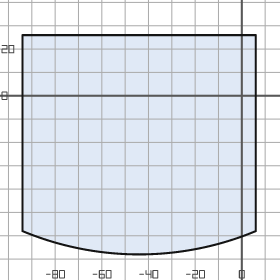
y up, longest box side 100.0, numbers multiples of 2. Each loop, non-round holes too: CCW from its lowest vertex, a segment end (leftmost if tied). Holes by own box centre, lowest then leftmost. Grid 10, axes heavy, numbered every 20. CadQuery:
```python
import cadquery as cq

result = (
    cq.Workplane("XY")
    .moveTo(-94.0, -58.0)
    .threePointArc((-44.0, -68.0), (6.0, -58.0))
    .lineTo(6.0, 26.0)
    .lineTo(-94.0, 26.0)
    .close()
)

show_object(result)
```